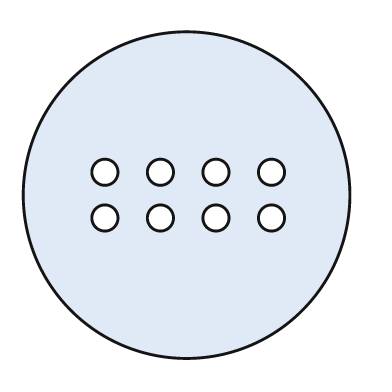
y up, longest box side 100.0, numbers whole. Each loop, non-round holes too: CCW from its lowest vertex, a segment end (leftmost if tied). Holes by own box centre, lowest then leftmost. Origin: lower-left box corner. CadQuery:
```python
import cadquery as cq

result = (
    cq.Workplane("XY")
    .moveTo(50.0, 50.0)
    .circle(50.0)
    .moveTo(25.0, 43.0)
    .circle(4.0)
    .moveTo(42.0, 43.0)
    .circle(4.0)
    .moveTo(59.0, 43.0)
    .circle(4.0)
    .moveTo(76.0, 43.0)
    .circle(4.0)
    .moveTo(25.0, 57.0)
    .circle(4.0)
    .moveTo(42.0, 57.0)
    .circle(4.0)
    .moveTo(59.0, 57.0)
    .circle(4.0)
    .moveTo(76.0, 57.0)
    .circle(4.0)
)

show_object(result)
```